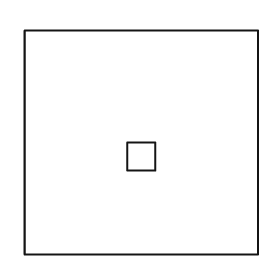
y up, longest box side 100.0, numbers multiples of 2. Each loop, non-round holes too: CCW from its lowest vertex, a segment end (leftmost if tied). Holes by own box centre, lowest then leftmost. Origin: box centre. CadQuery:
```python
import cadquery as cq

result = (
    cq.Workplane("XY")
    .moveTo(-50.0, -48.0)
    .lineTo(50.0, -48.0)
    .lineTo(50.0, 48.0)
    .lineTo(-50.0, 48.0)
    .close()
    .moveTo(-6.0, -12.0)
    .lineTo(6.0, -12.0)
    .lineTo(6.0, 0.0)
    .lineTo(-6.0, 0.0)
    .close()
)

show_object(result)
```